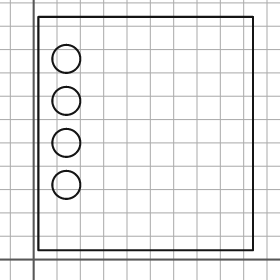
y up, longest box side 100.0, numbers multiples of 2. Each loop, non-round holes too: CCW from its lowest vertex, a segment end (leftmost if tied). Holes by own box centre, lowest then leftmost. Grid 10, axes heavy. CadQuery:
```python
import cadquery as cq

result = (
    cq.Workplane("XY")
    .moveTo(2.0, 4.0)
    .lineTo(94.0, 4.0)
    .lineTo(94.0, 104.0)
    .lineTo(2.0, 104.0)
    .close()
    .moveTo(14.0, 32.0)
    .circle(6.0)
    .moveTo(14.0, 50.0)
    .circle(6.0)
    .moveTo(14.0, 68.0)
    .circle(6.0)
    .moveTo(14.0, 86.0)
    .circle(6.0)
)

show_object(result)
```